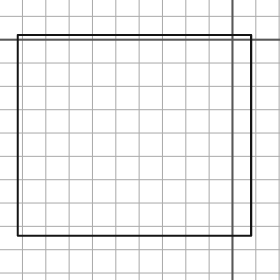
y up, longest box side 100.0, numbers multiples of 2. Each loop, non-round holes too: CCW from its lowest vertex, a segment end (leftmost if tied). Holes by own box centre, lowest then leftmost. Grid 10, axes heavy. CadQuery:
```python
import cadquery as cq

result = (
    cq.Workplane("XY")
    .moveTo(-92.0, -84.0)
    .lineTo(8.0, -84.0)
    .lineTo(8.0, 2.0)
    .lineTo(-92.0, 2.0)
    .close()
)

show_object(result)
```